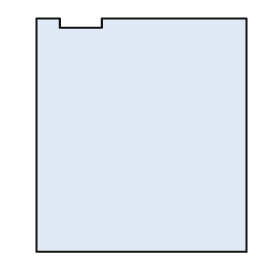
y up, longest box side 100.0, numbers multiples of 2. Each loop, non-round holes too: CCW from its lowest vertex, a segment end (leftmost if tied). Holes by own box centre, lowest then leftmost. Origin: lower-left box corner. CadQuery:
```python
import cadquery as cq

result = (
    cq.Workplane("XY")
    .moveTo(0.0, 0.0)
    .lineTo(90.0, 0.0)
    .lineTo(90.0, 100.0)
    .lineTo(28.0, 100.0)
    .lineTo(28.0, 96.0)
    .lineTo(10.0, 96.0)
    .lineTo(10.0, 100.0)
    .lineTo(0.0, 100.0)
    .close()
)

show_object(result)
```